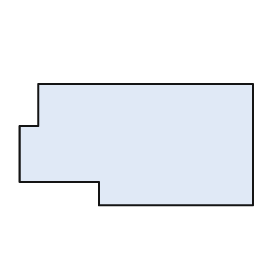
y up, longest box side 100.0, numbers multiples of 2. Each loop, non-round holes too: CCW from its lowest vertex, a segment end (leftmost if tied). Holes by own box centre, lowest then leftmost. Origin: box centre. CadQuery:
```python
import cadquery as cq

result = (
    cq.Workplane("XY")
    .moveTo(-16.0, -26.0)
    .lineTo(50.0, -26.0)
    .lineTo(50.0, 26.0)
    .lineTo(-42.0, 26.0)
    .lineTo(-42.0, 8.0)
    .lineTo(-50.0, 8.0)
    .lineTo(-50.0, -16.0)
    .lineTo(-16.0, -16.0)
    .close()
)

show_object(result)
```